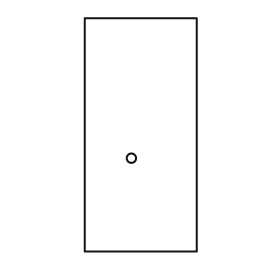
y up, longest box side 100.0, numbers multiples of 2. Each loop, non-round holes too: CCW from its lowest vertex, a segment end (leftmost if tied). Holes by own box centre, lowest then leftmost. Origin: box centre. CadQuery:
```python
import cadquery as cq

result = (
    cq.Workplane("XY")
    .moveTo(-24.0, -50.0)
    .lineTo(24.0, -50.0)
    .lineTo(24.0, 50.0)
    .lineTo(-24.0, 50.0)
    .close()
    .moveTo(-4.0, -10.0)
    .circle(2.0)
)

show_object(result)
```